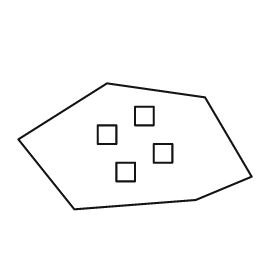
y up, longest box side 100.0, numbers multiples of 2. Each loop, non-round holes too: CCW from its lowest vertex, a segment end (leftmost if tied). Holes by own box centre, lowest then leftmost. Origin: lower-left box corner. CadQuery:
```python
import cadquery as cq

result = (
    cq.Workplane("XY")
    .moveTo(24.0, 0.0)
    .lineTo(76.0, 4.0)
    .lineTo(100.0, 14.0)
    .lineTo(80.0, 48.0)
    .lineTo(38.0, 54.0)
    .lineTo(0.0, 30.0)
    .close()
    .moveTo(42.0, 12.0)
    .lineTo(50.0, 12.0)
    .lineTo(50.0, 20.0)
    .lineTo(42.0, 20.0)
    .close()
    .moveTo(58.0, 20.0)
    .lineTo(66.0, 20.0)
    .lineTo(66.0, 28.0)
    .lineTo(58.0, 28.0)
    .close()
    .moveTo(34.0, 28.0)
    .lineTo(42.0, 28.0)
    .lineTo(42.0, 36.0)
    .lineTo(34.0, 36.0)
    .close()
    .moveTo(50.0, 36.0)
    .lineTo(58.0, 36.0)
    .lineTo(58.0, 44.0)
    .lineTo(50.0, 44.0)
    .close()
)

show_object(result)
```